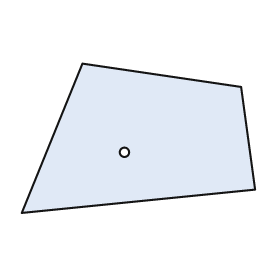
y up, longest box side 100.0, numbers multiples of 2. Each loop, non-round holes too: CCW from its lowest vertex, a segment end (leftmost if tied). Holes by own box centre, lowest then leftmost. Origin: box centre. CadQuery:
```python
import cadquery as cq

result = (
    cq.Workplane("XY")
    .moveTo(-50.0, -32.0)
    .lineTo(50.0, -22.0)
    .lineTo(44.0, 22.0)
    .lineTo(-24.0, 32.0)
    .close()
    .moveTo(-6.0, -6.0)
    .circle(2.0)
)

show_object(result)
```